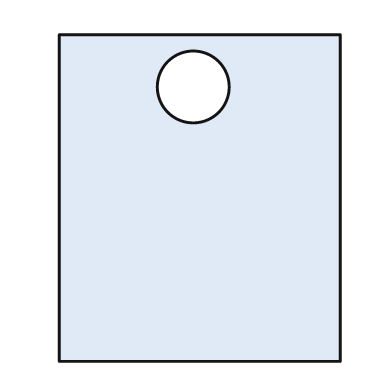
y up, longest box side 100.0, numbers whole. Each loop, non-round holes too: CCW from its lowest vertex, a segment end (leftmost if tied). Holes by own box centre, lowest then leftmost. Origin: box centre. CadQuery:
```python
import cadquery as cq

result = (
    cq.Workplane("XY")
    .moveTo(-43.0, -50.0)
    .lineTo(43.0, -50.0)
    .lineTo(43.0, 50.0)
    .lineTo(-43.0, 50.0)
    .close()
    .moveTo(-2.0, 34.0)
    .circle(11.0)
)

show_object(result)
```